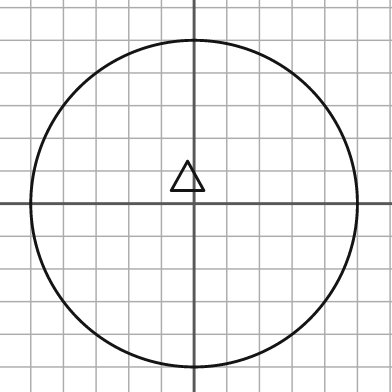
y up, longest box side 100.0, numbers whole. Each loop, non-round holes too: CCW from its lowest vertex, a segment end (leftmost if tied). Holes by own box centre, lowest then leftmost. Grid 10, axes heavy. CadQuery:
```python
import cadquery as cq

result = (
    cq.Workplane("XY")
    .moveTo(0.0, 0.0)
    .circle(50.0)
    .moveTo(-7.0, 4.0)
    .lineTo(3.0, 4.0)
    .lineTo(-2.0, 13.0)
    .close()
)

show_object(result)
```